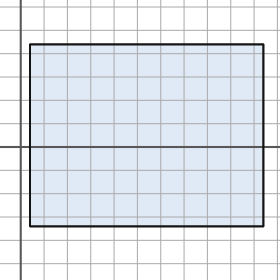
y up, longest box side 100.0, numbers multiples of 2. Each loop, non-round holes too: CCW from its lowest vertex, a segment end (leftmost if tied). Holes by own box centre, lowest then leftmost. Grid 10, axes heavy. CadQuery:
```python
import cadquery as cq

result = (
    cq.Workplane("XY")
    .moveTo(4.0, -34.0)
    .lineTo(104.0, -34.0)
    .lineTo(104.0, 44.0)
    .lineTo(4.0, 44.0)
    .close()
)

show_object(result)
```